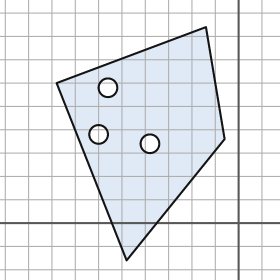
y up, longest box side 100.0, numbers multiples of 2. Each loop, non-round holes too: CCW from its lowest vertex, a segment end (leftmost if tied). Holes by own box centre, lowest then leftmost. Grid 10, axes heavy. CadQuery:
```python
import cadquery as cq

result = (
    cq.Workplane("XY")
    .moveTo(-48.0, -16.0)
    .lineTo(-6.0, 36.0)
    .lineTo(-14.0, 84.0)
    .lineTo(-78.0, 60.0)
    .close()
    .moveTo(-38.0, 34.0)
    .circle(4.0)
    .moveTo(-60.0, 38.0)
    .circle(4.0)
    .moveTo(-56.0, 58.0)
    .circle(4.0)
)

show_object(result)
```